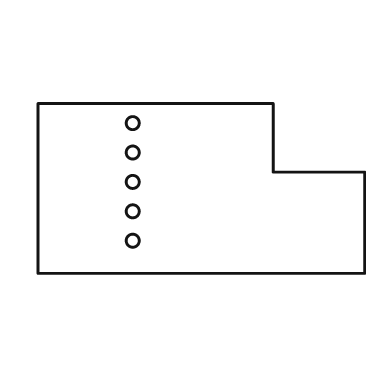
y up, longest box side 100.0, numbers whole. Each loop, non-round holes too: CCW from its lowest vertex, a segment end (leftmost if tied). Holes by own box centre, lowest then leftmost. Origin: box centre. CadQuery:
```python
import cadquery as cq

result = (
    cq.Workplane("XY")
    .moveTo(-50.0, -26.0)
    .lineTo(50.0, -26.0)
    .lineTo(50.0, 5.0)
    .lineTo(22.0, 5.0)
    .lineTo(22.0, 26.0)
    .lineTo(-50.0, 26.0)
    .close()
    .moveTo(-21.0, -16.0)
    .circle(2.0)
    .moveTo(-21.0, -7.0)
    .circle(2.0)
    .moveTo(-21.0, 2.0)
    .circle(2.0)
    .moveTo(-21.0, 11.0)
    .circle(2.0)
    .moveTo(-21.0, 20.0)
    .circle(2.0)
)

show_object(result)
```